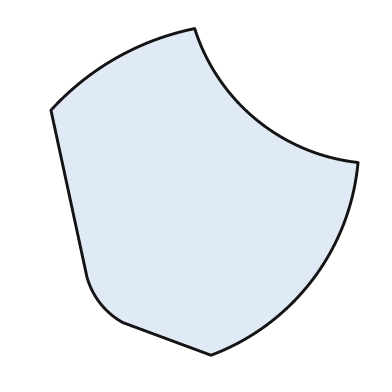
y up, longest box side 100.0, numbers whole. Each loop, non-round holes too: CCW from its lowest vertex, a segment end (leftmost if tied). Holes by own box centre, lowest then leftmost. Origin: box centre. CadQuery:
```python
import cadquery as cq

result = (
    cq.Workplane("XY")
    .moveTo(2.0, -50.0)
    .threePointArc((33.0, -27.0), (47.0, 9.0))
    .threePointArc((16.0, 22.0), (-3.0, 50.0))
    .threePointArc((-27.0, 41.0), (-47.0, 25.0))
    .lineTo(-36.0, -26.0)
    .threePointArc((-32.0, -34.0), (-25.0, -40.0))
    .close()
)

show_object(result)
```